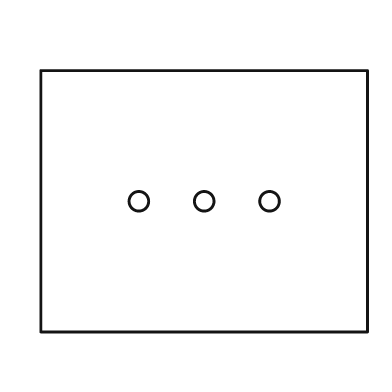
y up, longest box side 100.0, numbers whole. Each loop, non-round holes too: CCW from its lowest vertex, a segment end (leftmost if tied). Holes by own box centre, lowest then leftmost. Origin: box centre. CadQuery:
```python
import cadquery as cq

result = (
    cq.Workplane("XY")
    .moveTo(-50.0, -40.0)
    .lineTo(50.0, -40.0)
    .lineTo(50.0, 40.0)
    .lineTo(-50.0, 40.0)
    .close()
    .moveTo(-20.0, 0.0)
    .circle(3.0)
    .moveTo(0.0, 0.0)
    .circle(3.0)
    .moveTo(20.0, 0.0)
    .circle(3.0)
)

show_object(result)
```